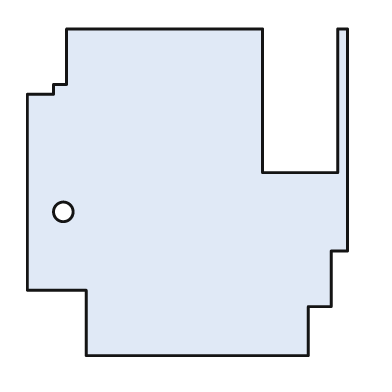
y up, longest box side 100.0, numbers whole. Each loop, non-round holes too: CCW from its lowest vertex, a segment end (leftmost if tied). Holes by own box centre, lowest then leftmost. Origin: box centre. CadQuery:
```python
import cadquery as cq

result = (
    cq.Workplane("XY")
    .moveTo(-31.0, -50.0)
    .lineTo(37.0, -50.0)
    .lineTo(37.0, -35.0)
    .lineTo(44.0, -35.0)
    .lineTo(44.0, -18.0)
    .lineTo(49.0, -18.0)
    .lineTo(49.0, 50.0)
    .lineTo(46.0, 50.0)
    .lineTo(46.0, 6.0)
    .lineTo(23.0, 6.0)
    .lineTo(23.0, 50.0)
    .lineTo(-37.0, 50.0)
    .lineTo(-37.0, 33.0)
    .lineTo(-41.0, 33.0)
    .lineTo(-41.0, 30.0)
    .lineTo(-49.0, 30.0)
    .lineTo(-49.0, -30.0)
    .lineTo(-31.0, -30.0)
    .close()
    .moveTo(-38.0, -6.0)
    .circle(3.0)
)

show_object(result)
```